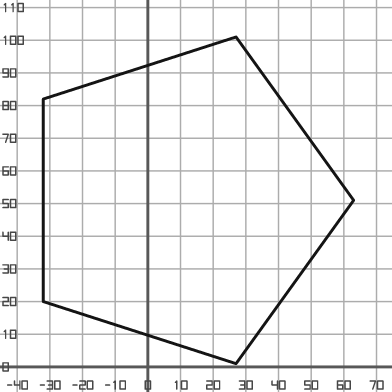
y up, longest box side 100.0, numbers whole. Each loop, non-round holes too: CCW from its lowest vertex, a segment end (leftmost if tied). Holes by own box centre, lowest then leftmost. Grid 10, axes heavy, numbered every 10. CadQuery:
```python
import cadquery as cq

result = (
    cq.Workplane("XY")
    .moveTo(27.0, 1.0)
    .lineTo(63.0, 51.0)
    .lineTo(27.0, 101.0)
    .lineTo(-32.0, 82.0)
    .lineTo(-32.0, 20.0)
    .close()
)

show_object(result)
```